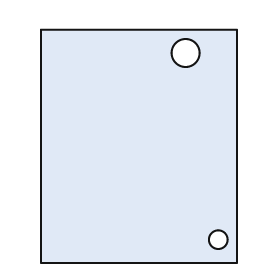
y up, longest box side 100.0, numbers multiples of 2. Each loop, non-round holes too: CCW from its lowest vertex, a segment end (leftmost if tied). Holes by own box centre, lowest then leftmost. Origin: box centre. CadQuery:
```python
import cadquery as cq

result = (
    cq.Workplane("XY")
    .moveTo(-42.0, -50.0)
    .lineTo(42.0, -50.0)
    .lineTo(42.0, 50.0)
    .lineTo(-42.0, 50.0)
    .close()
    .moveTo(34.0, -40.0)
    .circle(4.0)
    .moveTo(20.0, 40.0)
    .circle(6.0)
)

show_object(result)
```